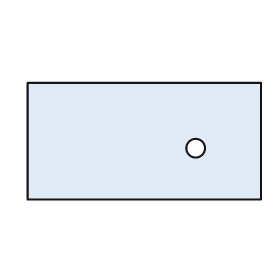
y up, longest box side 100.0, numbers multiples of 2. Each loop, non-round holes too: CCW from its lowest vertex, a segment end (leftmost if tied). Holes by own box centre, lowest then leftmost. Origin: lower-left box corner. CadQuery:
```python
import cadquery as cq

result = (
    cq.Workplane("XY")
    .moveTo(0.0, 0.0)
    .lineTo(100.0, 0.0)
    .lineTo(100.0, 50.0)
    .lineTo(0.0, 50.0)
    .close()
    .moveTo(72.0, 22.0)
    .circle(4.0)
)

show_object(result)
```